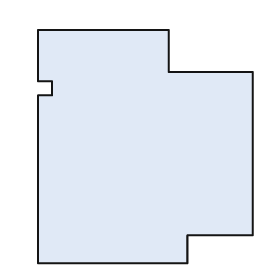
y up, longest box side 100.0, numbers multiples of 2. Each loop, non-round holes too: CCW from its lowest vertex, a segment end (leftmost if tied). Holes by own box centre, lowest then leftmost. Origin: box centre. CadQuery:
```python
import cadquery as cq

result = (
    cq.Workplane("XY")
    .moveTo(-46.0, -50.0)
    .lineTo(18.0, -50.0)
    .lineTo(18.0, -38.0)
    .lineTo(46.0, -38.0)
    .lineTo(46.0, 32.0)
    .lineTo(10.0, 32.0)
    .lineTo(10.0, 50.0)
    .lineTo(-46.0, 50.0)
    .lineTo(-46.0, 28.0)
    .lineTo(-40.0, 28.0)
    .lineTo(-40.0, 22.0)
    .lineTo(-46.0, 22.0)
    .close()
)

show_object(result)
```